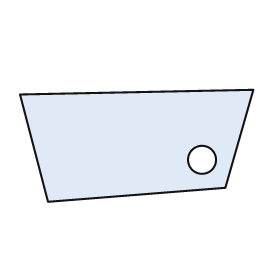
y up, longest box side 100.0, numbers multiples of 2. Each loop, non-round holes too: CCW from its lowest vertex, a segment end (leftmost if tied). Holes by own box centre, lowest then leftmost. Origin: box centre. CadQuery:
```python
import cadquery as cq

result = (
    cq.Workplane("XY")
    .moveTo(-38.0, -24.0)
    .lineTo(38.0, -18.0)
    .lineTo(50.0, 24.0)
    .lineTo(-50.0, 22.0)
    .close()
    .moveTo(28.0, -6.0)
    .circle(6.0)
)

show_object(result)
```